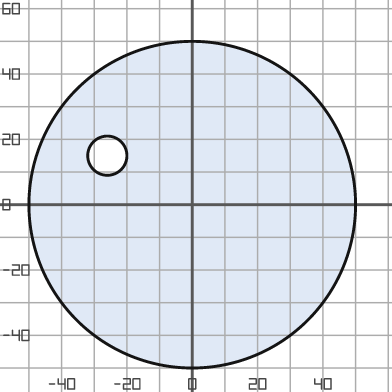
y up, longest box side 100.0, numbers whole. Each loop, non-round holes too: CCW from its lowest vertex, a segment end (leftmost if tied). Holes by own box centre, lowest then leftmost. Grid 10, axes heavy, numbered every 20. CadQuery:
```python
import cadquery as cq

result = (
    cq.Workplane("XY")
    .moveTo(0.0, 0.0)
    .circle(50.0)
    .moveTo(-26.0, 15.0)
    .circle(6.0)
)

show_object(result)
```